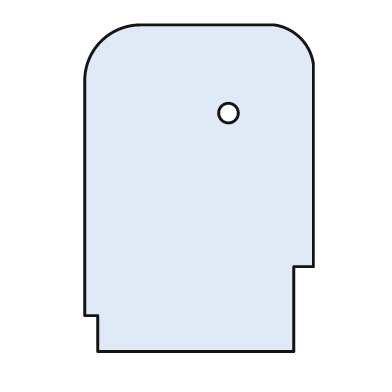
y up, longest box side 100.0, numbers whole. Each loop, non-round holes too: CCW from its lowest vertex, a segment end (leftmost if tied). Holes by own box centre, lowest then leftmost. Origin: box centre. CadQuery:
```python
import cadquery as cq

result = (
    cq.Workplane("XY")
    .moveTo(-31.0, -50.0)
    .lineTo(29.0, -50.0)
    .lineTo(29.0, -24.0)
    .lineTo(35.0, -24.0)
    .lineTo(35.0, 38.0)
    .threePointArc((31.0, 46.0), (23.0, 50.0))
    .lineTo(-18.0, 50.0)
    .threePointArc((-30.0, 45.0), (-35.0, 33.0))
    .lineTo(-35.0, -39.0)
    .lineTo(-31.0, -39.0)
    .close()
    .moveTo(9.0, 23.0)
    .circle(3.0)
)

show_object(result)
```